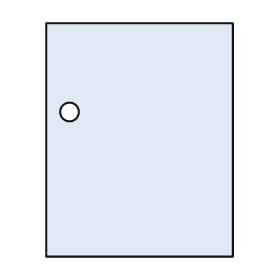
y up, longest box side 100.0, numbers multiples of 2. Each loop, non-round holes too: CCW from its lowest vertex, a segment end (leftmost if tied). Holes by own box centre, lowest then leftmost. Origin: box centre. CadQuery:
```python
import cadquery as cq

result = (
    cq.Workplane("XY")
    .moveTo(-40.0, -50.0)
    .lineTo(40.0, -50.0)
    .lineTo(40.0, 50.0)
    .lineTo(-40.0, 50.0)
    .close()
    .moveTo(-30.0, 12.0)
    .circle(4.0)
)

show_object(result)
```